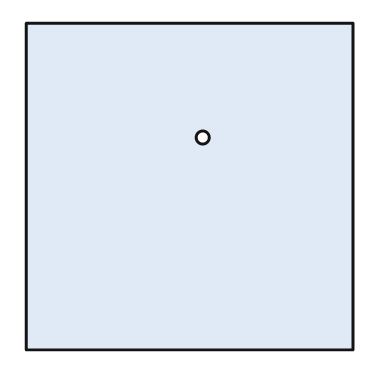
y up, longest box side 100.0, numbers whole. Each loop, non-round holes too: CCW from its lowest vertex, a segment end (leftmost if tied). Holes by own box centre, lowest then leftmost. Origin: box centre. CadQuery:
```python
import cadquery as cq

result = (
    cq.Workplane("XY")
    .moveTo(-50.0, -50.0)
    .lineTo(50.0, -50.0)
    .lineTo(50.0, 50.0)
    .lineTo(-50.0, 50.0)
    .close()
    .moveTo(4.0, 15.0)
    .circle(2.0)
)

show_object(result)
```